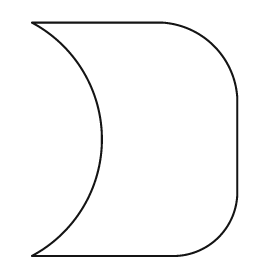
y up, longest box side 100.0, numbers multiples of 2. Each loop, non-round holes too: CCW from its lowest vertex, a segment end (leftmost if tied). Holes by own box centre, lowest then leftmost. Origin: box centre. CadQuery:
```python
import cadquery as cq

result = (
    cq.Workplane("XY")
    .moveTo(-44.0, -50.0)
    .lineTo(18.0, -50.0)
    .threePointArc((36.0, -42.0), (44.0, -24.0))
    .lineTo(44.0, 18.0)
    .threePointArc((34.0, 40.0), (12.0, 50.0))
    .lineTo(-44.0, 50.0)
    .threePointArc((-14.0, 0.0), (-44.0, -50.0))
    .close()
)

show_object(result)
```